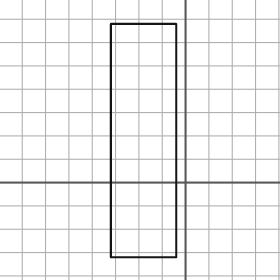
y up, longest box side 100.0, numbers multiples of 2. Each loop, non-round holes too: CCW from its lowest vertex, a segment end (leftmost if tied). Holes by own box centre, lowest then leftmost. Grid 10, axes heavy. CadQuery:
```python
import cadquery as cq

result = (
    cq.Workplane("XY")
    .moveTo(-32.0, -32.0)
    .lineTo(-4.0, -32.0)
    .lineTo(-4.0, 68.0)
    .lineTo(-32.0, 68.0)
    .close()
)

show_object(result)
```